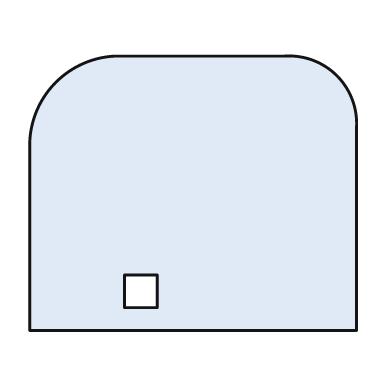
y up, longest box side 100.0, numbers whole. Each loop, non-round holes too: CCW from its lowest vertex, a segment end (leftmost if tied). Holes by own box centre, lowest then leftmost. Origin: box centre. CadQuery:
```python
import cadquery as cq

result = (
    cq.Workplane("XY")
    .moveTo(-50.0, -42.0)
    .lineTo(50.0, -42.0)
    .lineTo(50.0, 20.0)
    .threePointArc((44.0, 36.0), (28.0, 42.0))
    .lineTo(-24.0, 42.0)
    .threePointArc((-42.0, 34.0), (-50.0, 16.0))
    .close()
    .moveTo(-21.0, -35.0)
    .lineTo(-11.0, -35.0)
    .lineTo(-11.0, -25.0)
    .lineTo(-21.0, -25.0)
    .close()
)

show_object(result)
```